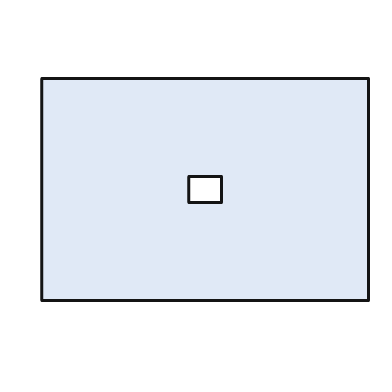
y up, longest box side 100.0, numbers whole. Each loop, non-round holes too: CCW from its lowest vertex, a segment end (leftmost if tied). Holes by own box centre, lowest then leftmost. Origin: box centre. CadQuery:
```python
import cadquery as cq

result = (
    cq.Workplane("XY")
    .moveTo(-50.0, -34.0)
    .lineTo(50.0, -34.0)
    .lineTo(50.0, 34.0)
    .lineTo(-50.0, 34.0)
    .close()
    .moveTo(-5.0, -4.0)
    .lineTo(5.0, -4.0)
    .lineTo(5.0, 4.0)
    .lineTo(-5.0, 4.0)
    .close()
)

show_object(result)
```